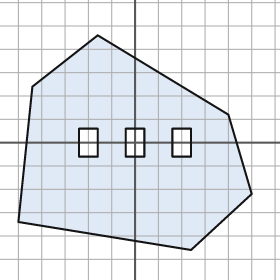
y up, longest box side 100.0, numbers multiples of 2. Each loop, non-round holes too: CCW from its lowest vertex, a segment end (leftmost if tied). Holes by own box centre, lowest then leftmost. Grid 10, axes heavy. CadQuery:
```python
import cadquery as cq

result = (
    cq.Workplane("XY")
    .moveTo(24.0, -46.0)
    .lineTo(50.0, -22.0)
    .lineTo(40.0, 12.0)
    .lineTo(-16.0, 46.0)
    .lineTo(-44.0, 24.0)
    .lineTo(-50.0, -34.0)
    .close()
    .moveTo(-24.0, -6.0)
    .lineTo(-16.0, -6.0)
    .lineTo(-16.0, 6.0)
    .lineTo(-24.0, 6.0)
    .close()
    .moveTo(-4.0, -6.0)
    .lineTo(4.0, -6.0)
    .lineTo(4.0, 6.0)
    .lineTo(-4.0, 6.0)
    .close()
    .moveTo(16.0, -6.0)
    .lineTo(24.0, -6.0)
    .lineTo(24.0, 6.0)
    .lineTo(16.0, 6.0)
    .close()
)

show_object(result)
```